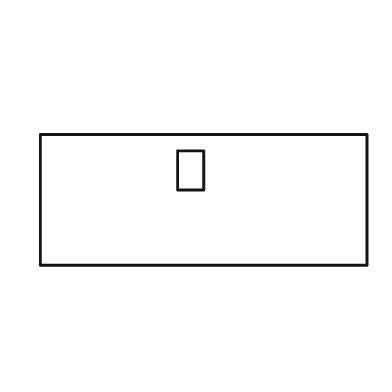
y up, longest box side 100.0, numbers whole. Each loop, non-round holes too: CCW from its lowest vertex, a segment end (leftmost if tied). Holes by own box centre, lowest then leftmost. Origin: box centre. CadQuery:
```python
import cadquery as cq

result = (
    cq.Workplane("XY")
    .moveTo(-50.0, -20.0)
    .lineTo(50.0, -20.0)
    .lineTo(50.0, 20.0)
    .lineTo(-50.0, 20.0)
    .close()
    .moveTo(-8.0, 3.0)
    .lineTo(0.0, 3.0)
    .lineTo(0.0, 15.0)
    .lineTo(-8.0, 15.0)
    .close()
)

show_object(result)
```